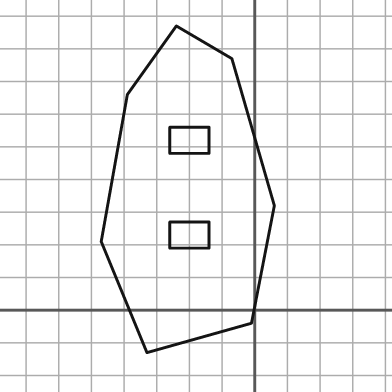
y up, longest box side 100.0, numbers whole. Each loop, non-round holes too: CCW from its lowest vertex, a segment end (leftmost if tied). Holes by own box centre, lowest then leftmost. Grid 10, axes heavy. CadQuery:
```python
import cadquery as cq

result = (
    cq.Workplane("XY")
    .moveTo(-33.0, -13.0)
    .lineTo(-1.0, -4.0)
    .lineTo(6.0, 32.0)
    .lineTo(-7.0, 77.0)
    .lineTo(-24.0, 87.0)
    .lineTo(-39.0, 66.0)
    .lineTo(-47.0, 21.0)
    .close()
    .moveTo(-26.0, 19.0)
    .lineTo(-14.0, 19.0)
    .lineTo(-14.0, 27.0)
    .lineTo(-26.0, 27.0)
    .close()
    .moveTo(-26.0, 48.0)
    .lineTo(-14.0, 48.0)
    .lineTo(-14.0, 56.0)
    .lineTo(-26.0, 56.0)
    .close()
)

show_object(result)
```